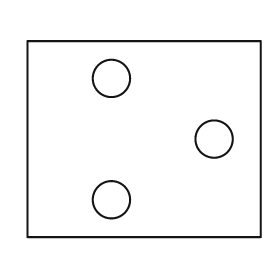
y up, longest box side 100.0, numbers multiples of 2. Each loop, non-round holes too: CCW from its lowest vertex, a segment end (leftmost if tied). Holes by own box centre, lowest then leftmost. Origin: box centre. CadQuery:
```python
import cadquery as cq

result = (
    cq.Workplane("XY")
    .moveTo(-50.0, -42.0)
    .lineTo(50.0, -42.0)
    .lineTo(50.0, 42.0)
    .lineTo(-50.0, 42.0)
    .close()
    .moveTo(-14.0, -26.0)
    .circle(8.0)
    .moveTo(30.0, 0.0)
    .circle(8.0)
    .moveTo(-14.0, 26.0)
    .circle(8.0)
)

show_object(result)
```